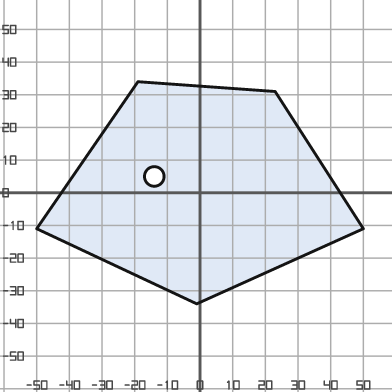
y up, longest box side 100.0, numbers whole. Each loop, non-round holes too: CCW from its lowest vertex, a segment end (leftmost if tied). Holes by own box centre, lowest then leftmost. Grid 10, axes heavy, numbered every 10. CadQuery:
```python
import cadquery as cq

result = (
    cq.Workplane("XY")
    .moveTo(-1.0, -34.0)
    .lineTo(50.0, -11.0)
    .lineTo(23.0, 31.0)
    .lineTo(-19.0, 34.0)
    .lineTo(-50.0, -11.0)
    .close()
    .moveTo(-14.0, 5.0)
    .circle(3.0)
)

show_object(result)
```